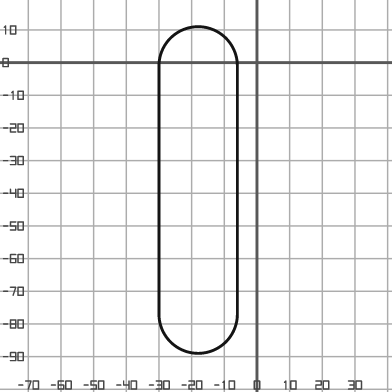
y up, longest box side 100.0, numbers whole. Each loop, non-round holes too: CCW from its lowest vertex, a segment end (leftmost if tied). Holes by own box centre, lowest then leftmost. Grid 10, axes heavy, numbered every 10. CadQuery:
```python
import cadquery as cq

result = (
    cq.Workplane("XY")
    .moveTo(-30.0, -77.0)
    .threePointArc((-18.0, -89.0), (-6.0, -77.0))
    .lineTo(-6.0, -1.0)
    .threePointArc((-18.0, 11.0), (-30.0, -1.0))
    .close()
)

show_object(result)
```